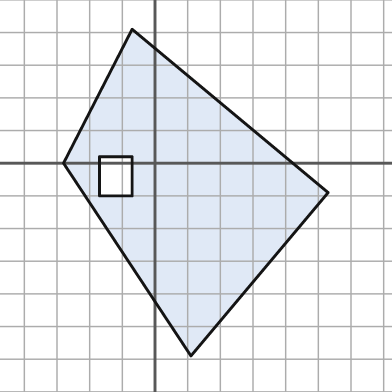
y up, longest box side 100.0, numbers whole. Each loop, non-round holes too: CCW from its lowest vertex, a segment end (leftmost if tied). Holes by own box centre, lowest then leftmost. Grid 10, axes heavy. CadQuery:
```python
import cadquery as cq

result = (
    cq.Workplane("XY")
    .moveTo(11.0, -59.0)
    .lineTo(53.0, -9.0)
    .lineTo(-7.0, 41.0)
    .lineTo(-28.0, 0.0)
    .close()
    .moveTo(-17.0, -10.0)
    .lineTo(-7.0, -10.0)
    .lineTo(-7.0, 2.0)
    .lineTo(-17.0, 2.0)
    .close()
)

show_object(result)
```